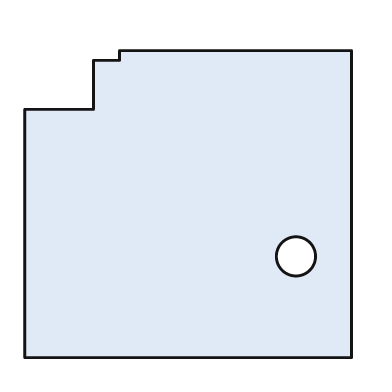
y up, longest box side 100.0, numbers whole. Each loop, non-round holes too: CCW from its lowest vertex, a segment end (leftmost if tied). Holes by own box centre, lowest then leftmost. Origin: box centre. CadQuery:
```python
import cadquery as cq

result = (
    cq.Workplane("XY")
    .moveTo(-50.0, -47.0)
    .lineTo(50.0, -47.0)
    .lineTo(50.0, 47.0)
    .lineTo(-21.0, 47.0)
    .lineTo(-21.0, 44.0)
    .lineTo(-29.0, 44.0)
    .lineTo(-29.0, 29.0)
    .lineTo(-50.0, 29.0)
    .close()
    .moveTo(33.0, -16.0)
    .circle(6.0)
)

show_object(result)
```